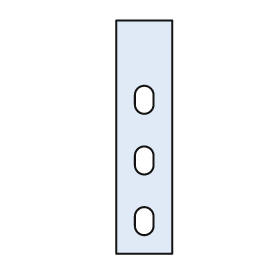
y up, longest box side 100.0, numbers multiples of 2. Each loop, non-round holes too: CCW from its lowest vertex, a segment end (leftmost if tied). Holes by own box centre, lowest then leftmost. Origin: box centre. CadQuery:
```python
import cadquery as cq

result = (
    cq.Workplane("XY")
    .moveTo(-12.0, -50.0)
    .lineTo(12.0, -50.0)
    .lineTo(12.0, 50.0)
    .lineTo(-12.0, 50.0)
    .close()
    .moveTo(-4.0, -38.0)
    .threePointArc((0.0, -42.0), (4.0, -38.0))
    .lineTo(4.0, -34.0)
    .threePointArc((0.0, -30.0), (-4.0, -34.0))
    .close()
    .moveTo(-4.0, -12.0)
    .threePointArc((0.0, -16.0), (4.0, -12.0))
    .lineTo(4.0, -8.0)
    .threePointArc((0.0, -4.0), (-4.0, -8.0))
    .close()
    .moveTo(-4.0, 14.0)
    .threePointArc((0.0, 10.0), (4.0, 14.0))
    .lineTo(4.0, 18.0)
    .threePointArc((0.0, 22.0), (-4.0, 18.0))
    .close()
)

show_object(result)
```